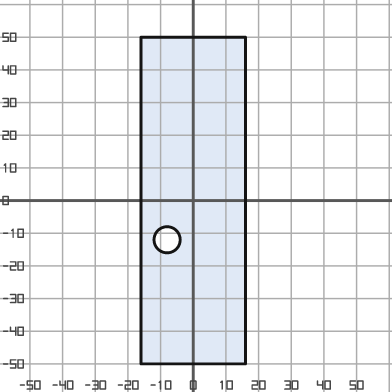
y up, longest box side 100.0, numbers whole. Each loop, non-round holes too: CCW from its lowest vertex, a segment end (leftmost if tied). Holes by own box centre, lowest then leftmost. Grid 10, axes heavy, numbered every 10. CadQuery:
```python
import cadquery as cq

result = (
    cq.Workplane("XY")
    .moveTo(-16.0, -50.0)
    .lineTo(16.0, -50.0)
    .lineTo(16.0, 50.0)
    .lineTo(-16.0, 50.0)
    .close()
    .moveTo(-8.0, -12.0)
    .circle(4.0)
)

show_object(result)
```